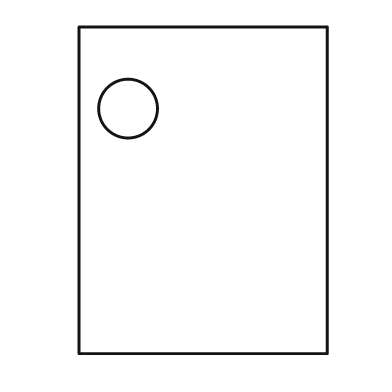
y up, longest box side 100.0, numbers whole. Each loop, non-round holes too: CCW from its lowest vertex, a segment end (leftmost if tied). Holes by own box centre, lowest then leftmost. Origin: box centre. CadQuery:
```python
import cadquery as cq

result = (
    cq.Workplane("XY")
    .moveTo(-38.0, -50.0)
    .lineTo(38.0, -50.0)
    .lineTo(38.0, 50.0)
    .lineTo(-38.0, 50.0)
    .close()
    .moveTo(-23.0, 25.0)
    .circle(9.0)
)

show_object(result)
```